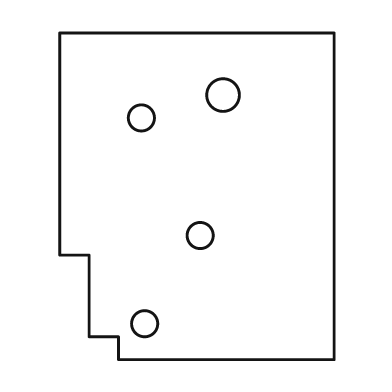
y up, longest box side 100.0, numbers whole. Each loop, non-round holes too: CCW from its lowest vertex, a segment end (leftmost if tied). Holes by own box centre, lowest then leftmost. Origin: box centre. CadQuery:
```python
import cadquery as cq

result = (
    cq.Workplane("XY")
    .moveTo(-24.0, -50.0)
    .lineTo(42.0, -50.0)
    .lineTo(42.0, 50.0)
    .lineTo(-42.0, 50.0)
    .lineTo(-42.0, -18.0)
    .lineTo(-33.0, -18.0)
    .lineTo(-33.0, -43.0)
    .lineTo(-24.0, -43.0)
    .close()
    .moveTo(-16.0, -39.0)
    .circle(4.0)
    .moveTo(1.0, -12.0)
    .circle(4.0)
    .moveTo(-17.0, 24.0)
    .circle(4.0)
    .moveTo(8.0, 31.0)
    .circle(5.0)
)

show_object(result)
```